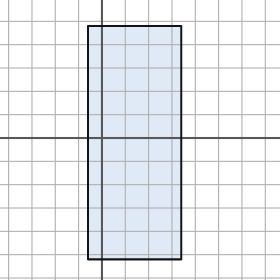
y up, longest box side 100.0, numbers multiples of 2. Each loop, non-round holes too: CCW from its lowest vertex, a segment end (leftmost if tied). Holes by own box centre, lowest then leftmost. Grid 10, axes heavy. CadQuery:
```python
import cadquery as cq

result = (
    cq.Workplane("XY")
    .moveTo(-6.0, -52.0)
    .lineTo(34.0, -52.0)
    .lineTo(34.0, 48.0)
    .lineTo(-6.0, 48.0)
    .close()
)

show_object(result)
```